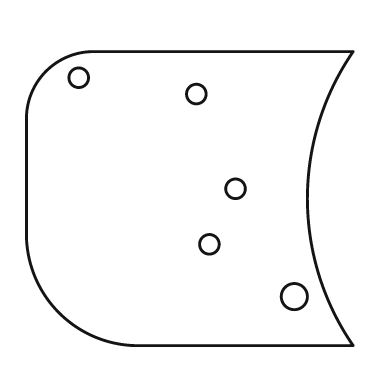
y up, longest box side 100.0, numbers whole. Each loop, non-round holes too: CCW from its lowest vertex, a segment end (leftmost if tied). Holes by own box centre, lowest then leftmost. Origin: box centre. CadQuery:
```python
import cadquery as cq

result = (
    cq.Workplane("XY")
    .moveTo(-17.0, -45.0)
    .lineTo(50.0, -45.0)
    .threePointArc((36.0, 0.0), (50.0, 45.0))
    .lineTo(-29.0, 45.0)
    .threePointArc((-44.0, 39.0), (-50.0, 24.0))
    .lineTo(-50.0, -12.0)
    .threePointArc((-40.0, -35.0), (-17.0, -45.0))
    .close()
    .moveTo(32.0, -30.0)
    .circle(4.0)
    .moveTo(6.0, -14.0)
    .circle(3.0)
    .moveTo(14.0, 3.0)
    .circle(3.0)
    .moveTo(2.0, 32.0)
    .circle(3.0)
    .moveTo(-34.0, 37.0)
    .circle(3.0)
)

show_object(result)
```